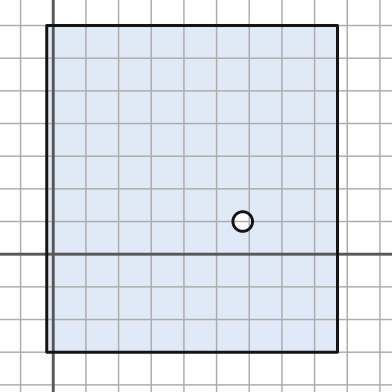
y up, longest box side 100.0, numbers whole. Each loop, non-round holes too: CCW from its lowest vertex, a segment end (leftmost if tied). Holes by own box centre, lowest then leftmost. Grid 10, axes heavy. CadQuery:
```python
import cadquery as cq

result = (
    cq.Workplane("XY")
    .moveTo(-2.0, -30.0)
    .lineTo(87.0, -30.0)
    .lineTo(87.0, 70.0)
    .lineTo(-2.0, 70.0)
    .close()
    .moveTo(58.0, 10.0)
    .circle(3.0)
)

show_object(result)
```